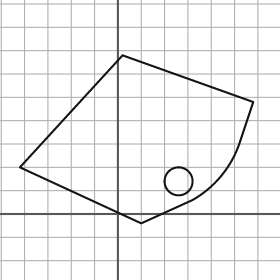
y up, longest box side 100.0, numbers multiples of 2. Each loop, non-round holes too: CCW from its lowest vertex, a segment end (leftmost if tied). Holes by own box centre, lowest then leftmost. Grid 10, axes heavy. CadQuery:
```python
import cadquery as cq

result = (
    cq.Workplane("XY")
    .moveTo(10.0, -4.0)
    .lineTo(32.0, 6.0)
    .threePointArc((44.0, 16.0), (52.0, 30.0))
    .lineTo(58.0, 48.0)
    .lineTo(2.0, 68.0)
    .lineTo(-42.0, 20.0)
    .close()
    .moveTo(26.0, 14.0)
    .circle(6.0)
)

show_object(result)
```